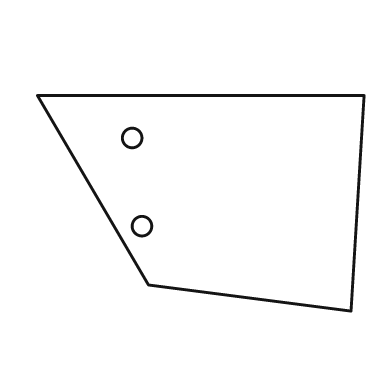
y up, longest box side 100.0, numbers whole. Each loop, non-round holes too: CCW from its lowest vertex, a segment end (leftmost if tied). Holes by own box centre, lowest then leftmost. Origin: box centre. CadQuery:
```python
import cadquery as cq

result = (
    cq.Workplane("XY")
    .moveTo(46.0, -33.0)
    .lineTo(50.0, 33.0)
    .lineTo(-50.0, 33.0)
    .lineTo(-16.0, -25.0)
    .close()
    .moveTo(-18.0, -7.0)
    .circle(3.0)
    .moveTo(-21.0, 20.0)
    .circle(3.0)
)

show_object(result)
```